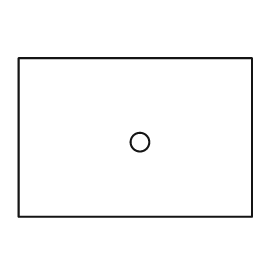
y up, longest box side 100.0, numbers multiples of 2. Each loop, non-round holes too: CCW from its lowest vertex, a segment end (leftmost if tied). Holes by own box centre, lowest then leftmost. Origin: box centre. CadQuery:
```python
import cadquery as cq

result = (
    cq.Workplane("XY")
    .moveTo(-50.0, -34.0)
    .lineTo(50.0, -34.0)
    .lineTo(50.0, 34.0)
    .lineTo(-50.0, 34.0)
    .close()
    .moveTo(2.0, -2.0)
    .circle(4.0)
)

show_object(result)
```